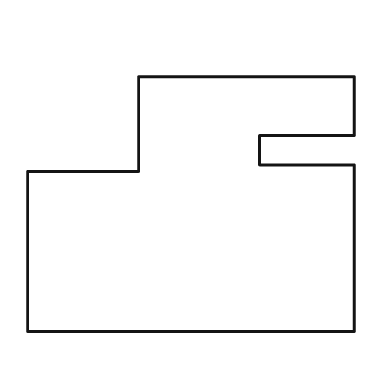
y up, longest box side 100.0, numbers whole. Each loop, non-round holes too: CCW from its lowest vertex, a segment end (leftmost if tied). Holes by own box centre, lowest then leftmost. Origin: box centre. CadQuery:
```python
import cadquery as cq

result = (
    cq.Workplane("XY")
    .moveTo(-50.0, -39.0)
    .lineTo(50.0, -39.0)
    .lineTo(50.0, 12.0)
    .lineTo(21.0, 12.0)
    .lineTo(21.0, 21.0)
    .lineTo(50.0, 21.0)
    .lineTo(50.0, 39.0)
    .lineTo(-16.0, 39.0)
    .lineTo(-16.0, 10.0)
    .lineTo(-50.0, 10.0)
    .close()
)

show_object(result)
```